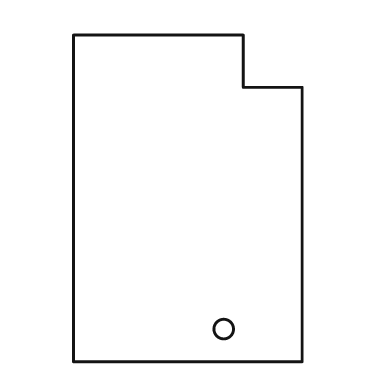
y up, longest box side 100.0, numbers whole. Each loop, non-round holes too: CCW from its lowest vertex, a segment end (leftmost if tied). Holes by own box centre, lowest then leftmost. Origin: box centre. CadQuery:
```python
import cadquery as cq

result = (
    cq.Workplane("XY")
    .moveTo(-35.0, -50.0)
    .lineTo(35.0, -50.0)
    .lineTo(35.0, 34.0)
    .lineTo(17.0, 34.0)
    .lineTo(17.0, 50.0)
    .lineTo(-35.0, 50.0)
    .close()
    .moveTo(11.0, -40.0)
    .circle(3.0)
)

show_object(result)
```